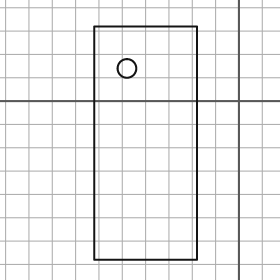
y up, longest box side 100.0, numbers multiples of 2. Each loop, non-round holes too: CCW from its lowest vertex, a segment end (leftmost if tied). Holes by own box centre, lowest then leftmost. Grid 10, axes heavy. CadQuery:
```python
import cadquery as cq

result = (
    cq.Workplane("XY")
    .moveTo(-62.0, -68.0)
    .lineTo(-18.0, -68.0)
    .lineTo(-18.0, 32.0)
    .lineTo(-62.0, 32.0)
    .close()
    .moveTo(-48.0, 14.0)
    .circle(4.0)
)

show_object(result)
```